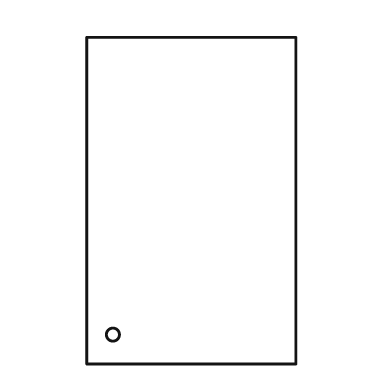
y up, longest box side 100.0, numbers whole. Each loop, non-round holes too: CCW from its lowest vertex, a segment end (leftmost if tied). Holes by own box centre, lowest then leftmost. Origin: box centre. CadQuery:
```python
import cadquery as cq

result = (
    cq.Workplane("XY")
    .moveTo(-32.0, -50.0)
    .lineTo(32.0, -50.0)
    .lineTo(32.0, 50.0)
    .lineTo(-32.0, 50.0)
    .close()
    .moveTo(-24.0, -41.0)
    .circle(2.0)
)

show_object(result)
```